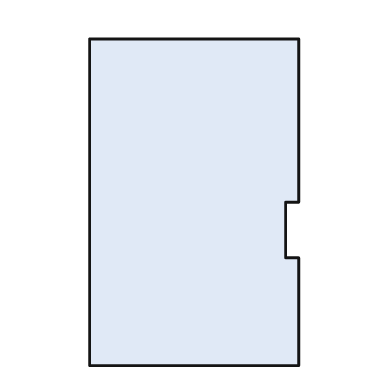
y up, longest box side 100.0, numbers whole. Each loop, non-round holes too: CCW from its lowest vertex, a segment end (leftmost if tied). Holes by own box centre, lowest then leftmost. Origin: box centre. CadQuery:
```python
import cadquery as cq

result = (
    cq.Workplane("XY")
    .moveTo(-32.0, -50.0)
    .lineTo(32.0, -50.0)
    .lineTo(32.0, -17.0)
    .lineTo(28.0, -17.0)
    .lineTo(28.0, 0.0)
    .lineTo(32.0, 0.0)
    .lineTo(32.0, 50.0)
    .lineTo(-32.0, 50.0)
    .close()
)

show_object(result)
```